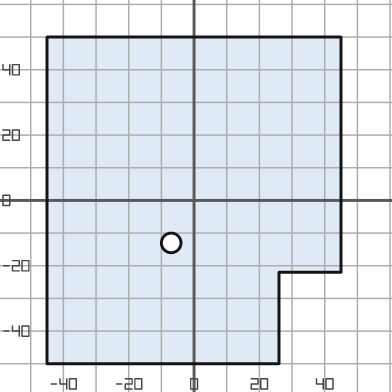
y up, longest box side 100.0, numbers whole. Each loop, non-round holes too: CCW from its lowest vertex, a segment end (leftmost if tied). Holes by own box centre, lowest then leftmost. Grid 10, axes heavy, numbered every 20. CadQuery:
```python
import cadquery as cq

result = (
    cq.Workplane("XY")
    .moveTo(-45.0, -50.0)
    .lineTo(26.0, -50.0)
    .lineTo(26.0, -22.0)
    .lineTo(45.0, -22.0)
    .lineTo(45.0, 50.0)
    .lineTo(-45.0, 50.0)
    .close()
    .moveTo(-7.0, -13.0)
    .circle(3.0)
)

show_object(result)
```